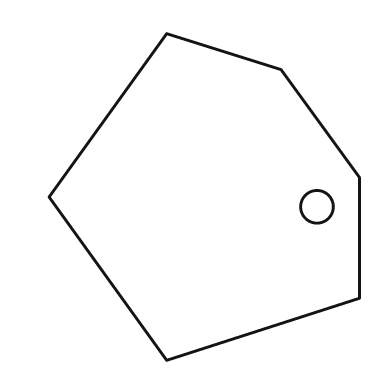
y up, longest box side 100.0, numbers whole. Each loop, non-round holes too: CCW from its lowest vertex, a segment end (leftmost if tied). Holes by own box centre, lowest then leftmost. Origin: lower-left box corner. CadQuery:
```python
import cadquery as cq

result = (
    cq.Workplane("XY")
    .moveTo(36.0, 0.0)
    .lineTo(95.0, 19.0)
    .lineTo(95.0, 56.0)
    .lineTo(71.0, 89.0)
    .lineTo(36.0, 100.0)
    .lineTo(0.0, 50.0)
    .close()
    .moveTo(82.0, 47.0)
    .circle(5.0)
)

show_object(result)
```